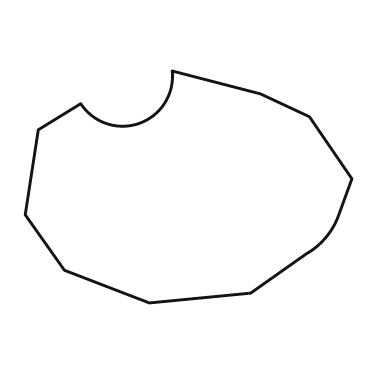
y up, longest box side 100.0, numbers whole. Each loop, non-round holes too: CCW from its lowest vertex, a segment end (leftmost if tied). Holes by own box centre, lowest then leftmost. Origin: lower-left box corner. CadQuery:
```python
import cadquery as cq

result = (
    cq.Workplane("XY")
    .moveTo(38.0, 0.0)
    .lineTo(69.0, 3.0)
    .lineTo(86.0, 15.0)
    .threePointArc((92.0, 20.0), (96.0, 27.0))
    .lineTo(100.0, 38.0)
    .lineTo(87.0, 57.0)
    .lineTo(72.0, 64.0)
    .lineTo(45.0, 71.0)
    .threePointArc((35.0, 55.0), (17.0, 61.0))
    .lineTo(4.0, 53.0)
    .lineTo(0.0, 27.0)
    .lineTo(12.0, 10.0)
    .close()
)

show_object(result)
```